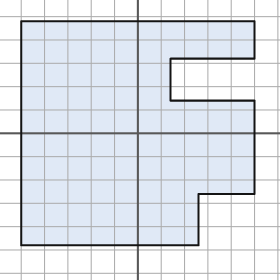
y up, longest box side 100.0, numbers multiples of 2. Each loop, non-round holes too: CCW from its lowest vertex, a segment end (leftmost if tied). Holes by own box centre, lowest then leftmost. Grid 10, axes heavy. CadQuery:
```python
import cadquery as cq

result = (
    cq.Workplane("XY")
    .moveTo(-50.0, -48.0)
    .lineTo(26.0, -48.0)
    .lineTo(26.0, -26.0)
    .lineTo(50.0, -26.0)
    .lineTo(50.0, 14.0)
    .lineTo(14.0, 14.0)
    .lineTo(14.0, 32.0)
    .lineTo(50.0, 32.0)
    .lineTo(50.0, 48.0)
    .lineTo(-50.0, 48.0)
    .close()
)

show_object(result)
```